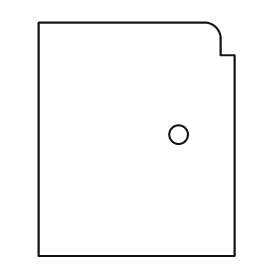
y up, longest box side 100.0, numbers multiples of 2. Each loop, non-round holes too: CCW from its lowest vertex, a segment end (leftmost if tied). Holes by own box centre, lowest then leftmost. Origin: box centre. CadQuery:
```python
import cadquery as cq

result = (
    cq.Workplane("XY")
    .moveTo(-42.0, -50.0)
    .lineTo(42.0, -50.0)
    .lineTo(42.0, 36.0)
    .lineTo(36.0, 36.0)
    .lineTo(36.0, 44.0)
    .threePointArc((34.0, 48.0), (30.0, 50.0))
    .lineTo(-42.0, 50.0)
    .close()
    .moveTo(18.0, 2.0)
    .circle(4.0)
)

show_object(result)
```